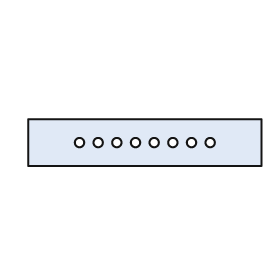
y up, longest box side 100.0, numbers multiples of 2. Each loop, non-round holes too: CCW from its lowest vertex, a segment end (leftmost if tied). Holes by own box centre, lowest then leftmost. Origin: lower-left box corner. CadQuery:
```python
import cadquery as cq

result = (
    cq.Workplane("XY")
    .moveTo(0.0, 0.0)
    .lineTo(100.0, 0.0)
    .lineTo(100.0, 20.0)
    .lineTo(0.0, 20.0)
    .close()
    .moveTo(22.0, 10.0)
    .circle(2.0)
    .moveTo(30.0, 10.0)
    .circle(2.0)
    .moveTo(38.0, 10.0)
    .circle(2.0)
    .moveTo(46.0, 10.0)
    .circle(2.0)
    .moveTo(54.0, 10.0)
    .circle(2.0)
    .moveTo(62.0, 10.0)
    .circle(2.0)
    .moveTo(70.0, 10.0)
    .circle(2.0)
    .moveTo(78.0, 10.0)
    .circle(2.0)
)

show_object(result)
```